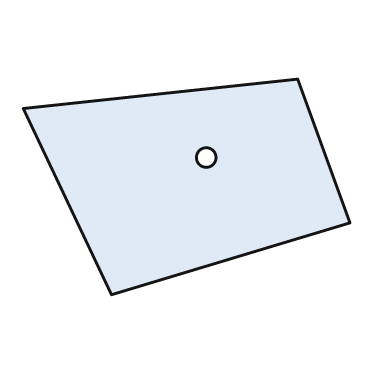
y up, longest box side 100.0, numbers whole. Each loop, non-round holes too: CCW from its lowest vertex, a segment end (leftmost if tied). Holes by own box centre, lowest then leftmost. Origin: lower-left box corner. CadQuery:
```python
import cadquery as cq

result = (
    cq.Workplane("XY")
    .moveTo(27.0, 0.0)
    .lineTo(100.0, 22.0)
    .lineTo(84.0, 66.0)
    .lineTo(0.0, 57.0)
    .close()
    .moveTo(56.0, 42.0)
    .circle(3.0)
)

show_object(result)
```